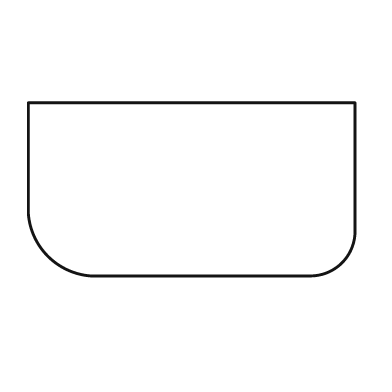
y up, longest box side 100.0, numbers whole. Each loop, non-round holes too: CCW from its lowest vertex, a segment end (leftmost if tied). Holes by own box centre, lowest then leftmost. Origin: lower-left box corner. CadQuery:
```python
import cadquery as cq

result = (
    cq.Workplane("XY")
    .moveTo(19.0, 0.0)
    .lineTo(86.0, 0.0)
    .threePointArc((96.0, 4.0), (100.0, 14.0))
    .lineTo(100.0, 53.0)
    .lineTo(0.0, 53.0)
    .lineTo(0.0, 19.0)
    .threePointArc((6.0, 6.0), (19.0, 0.0))
    .close()
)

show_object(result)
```